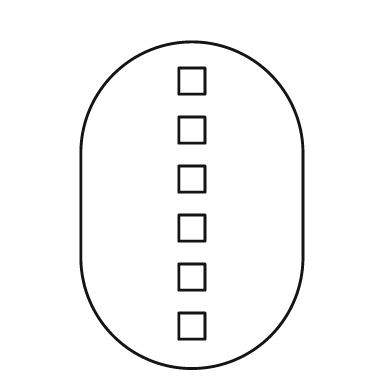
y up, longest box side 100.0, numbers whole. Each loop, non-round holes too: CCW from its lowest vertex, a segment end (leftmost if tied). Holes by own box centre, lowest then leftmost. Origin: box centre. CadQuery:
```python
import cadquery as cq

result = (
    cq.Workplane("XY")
    .moveTo(-34.0, -16.0)
    .threePointArc((0.0, -50.0), (34.0, -16.0))
    .lineTo(34.0, 16.0)
    .threePointArc((0.0, 50.0), (-34.0, 16.0))
    .close()
    .moveTo(-4.0, -41.0)
    .lineTo(4.0, -41.0)
    .lineTo(4.0, -33.0)
    .lineTo(-4.0, -33.0)
    .close()
    .moveTo(-4.0, -26.0)
    .lineTo(4.0, -26.0)
    .lineTo(4.0, -18.0)
    .lineTo(-4.0, -18.0)
    .close()
    .moveTo(-4.0, -11.0)
    .lineTo(4.0, -11.0)
    .lineTo(4.0, -3.0)
    .lineTo(-4.0, -3.0)
    .close()
    .moveTo(-4.0, 4.0)
    .lineTo(4.0, 4.0)
    .lineTo(4.0, 12.0)
    .lineTo(-4.0, 12.0)
    .close()
    .moveTo(-4.0, 19.0)
    .lineTo(4.0, 19.0)
    .lineTo(4.0, 27.0)
    .lineTo(-4.0, 27.0)
    .close()
    .moveTo(-4.0, 34.0)
    .lineTo(4.0, 34.0)
    .lineTo(4.0, 42.0)
    .lineTo(-4.0, 42.0)
    .close()
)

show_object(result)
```